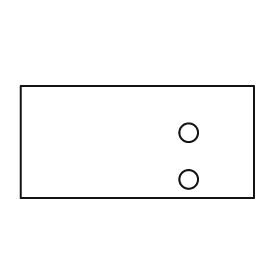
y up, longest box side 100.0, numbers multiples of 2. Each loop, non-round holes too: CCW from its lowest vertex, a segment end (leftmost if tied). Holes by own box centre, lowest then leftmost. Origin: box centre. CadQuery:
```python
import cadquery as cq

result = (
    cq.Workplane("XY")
    .moveTo(-50.0, -24.0)
    .lineTo(50.0, -24.0)
    .lineTo(50.0, 24.0)
    .lineTo(-50.0, 24.0)
    .close()
    .moveTo(22.0, -16.0)
    .circle(4.0)
    .moveTo(22.0, 4.0)
    .circle(4.0)
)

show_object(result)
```